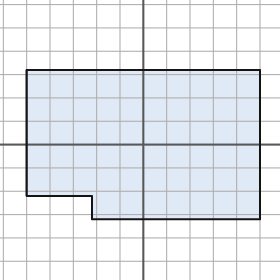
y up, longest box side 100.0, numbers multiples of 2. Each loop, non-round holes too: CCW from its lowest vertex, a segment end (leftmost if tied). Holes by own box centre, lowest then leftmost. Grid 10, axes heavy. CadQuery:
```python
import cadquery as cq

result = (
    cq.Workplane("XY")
    .moveTo(-22.0, -32.0)
    .lineTo(50.0, -32.0)
    .lineTo(50.0, 32.0)
    .lineTo(-50.0, 32.0)
    .lineTo(-50.0, -22.0)
    .lineTo(-22.0, -22.0)
    .close()
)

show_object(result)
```